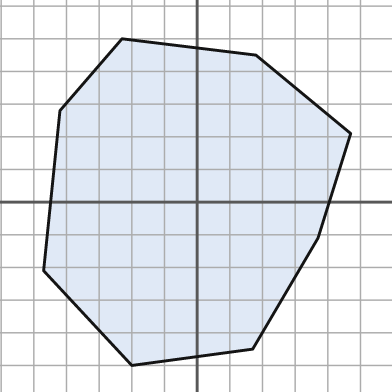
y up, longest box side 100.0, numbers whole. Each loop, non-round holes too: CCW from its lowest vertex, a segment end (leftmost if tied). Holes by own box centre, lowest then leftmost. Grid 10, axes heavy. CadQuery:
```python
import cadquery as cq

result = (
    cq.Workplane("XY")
    .moveTo(-20.0, -50.0)
    .lineTo(17.0, -45.0)
    .lineTo(37.0, -11.0)
    .lineTo(47.0, 21.0)
    .lineTo(18.0, 45.0)
    .lineTo(-23.0, 50.0)
    .lineTo(-42.0, 28.0)
    .lineTo(-47.0, -21.0)
    .close()
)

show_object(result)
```